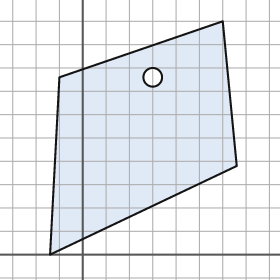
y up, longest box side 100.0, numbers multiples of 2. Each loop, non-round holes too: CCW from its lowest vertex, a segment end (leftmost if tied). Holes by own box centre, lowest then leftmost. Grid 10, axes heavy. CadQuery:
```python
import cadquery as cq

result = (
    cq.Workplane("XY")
    .moveTo(-14.0, 0.0)
    .lineTo(66.0, 38.0)
    .lineTo(60.0, 100.0)
    .lineTo(-10.0, 76.0)
    .close()
    .moveTo(30.0, 76.0)
    .circle(4.0)
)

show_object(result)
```